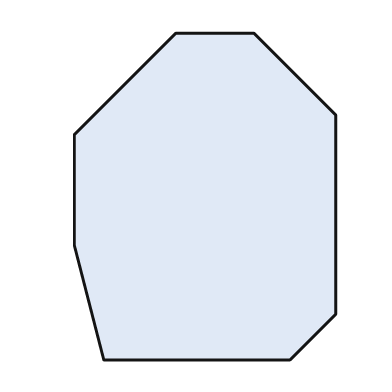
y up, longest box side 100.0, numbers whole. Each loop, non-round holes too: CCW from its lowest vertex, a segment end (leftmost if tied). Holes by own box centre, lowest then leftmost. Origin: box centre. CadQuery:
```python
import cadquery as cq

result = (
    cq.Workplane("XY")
    .moveTo(-31.0, -50.0)
    .lineTo(26.0, -50.0)
    .lineTo(40.0, -36.0)
    .lineTo(40.0, 25.0)
    .lineTo(15.0, 50.0)
    .lineTo(-9.0, 50.0)
    .lineTo(-40.0, 19.0)
    .lineTo(-40.0, -15.0)
    .close()
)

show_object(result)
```